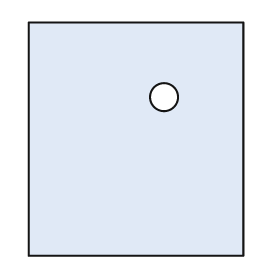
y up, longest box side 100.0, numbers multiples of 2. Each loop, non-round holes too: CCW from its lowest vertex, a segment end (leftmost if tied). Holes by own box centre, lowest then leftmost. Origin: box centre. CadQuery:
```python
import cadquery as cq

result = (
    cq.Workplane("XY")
    .moveTo(-46.0, -50.0)
    .lineTo(46.0, -50.0)
    .lineTo(46.0, 50.0)
    .lineTo(-46.0, 50.0)
    .close()
    .moveTo(12.0, 18.0)
    .circle(6.0)
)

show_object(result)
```